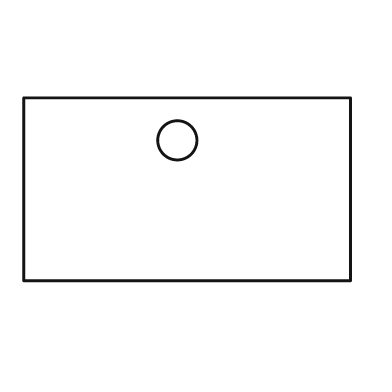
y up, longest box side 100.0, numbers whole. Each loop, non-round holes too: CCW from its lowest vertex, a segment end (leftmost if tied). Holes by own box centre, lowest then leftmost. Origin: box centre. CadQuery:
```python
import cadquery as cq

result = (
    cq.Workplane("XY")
    .moveTo(-50.0, -28.0)
    .lineTo(50.0, -28.0)
    .lineTo(50.0, 28.0)
    .lineTo(-50.0, 28.0)
    .close()
    .moveTo(-3.0, 15.0)
    .circle(6.0)
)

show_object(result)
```